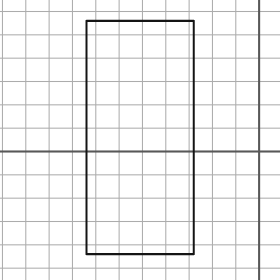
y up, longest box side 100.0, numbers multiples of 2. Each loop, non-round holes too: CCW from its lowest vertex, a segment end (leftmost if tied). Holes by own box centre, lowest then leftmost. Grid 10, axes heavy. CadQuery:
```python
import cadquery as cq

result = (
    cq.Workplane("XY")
    .moveTo(-74.0, -44.0)
    .lineTo(-28.0, -44.0)
    .lineTo(-28.0, 56.0)
    .lineTo(-74.0, 56.0)
    .close()
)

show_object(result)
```